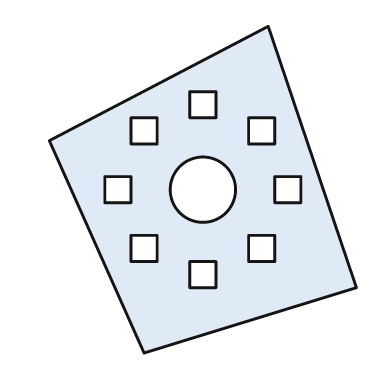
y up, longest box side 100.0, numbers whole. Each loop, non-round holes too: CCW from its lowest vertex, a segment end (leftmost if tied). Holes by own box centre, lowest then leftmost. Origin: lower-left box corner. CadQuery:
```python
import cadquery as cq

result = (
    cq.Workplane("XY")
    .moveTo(29.0, 0.0)
    .lineTo(94.0, 20.0)
    .lineTo(67.0, 100.0)
    .lineTo(0.0, 65.0)
    .close()
    .moveTo(43.0, 20.0)
    .lineTo(51.0, 20.0)
    .lineTo(51.0, 28.0)
    .lineTo(43.0, 28.0)
    .close()
    .moveTo(25.0, 28.0)
    .lineTo(33.0, 28.0)
    .lineTo(33.0, 36.0)
    .lineTo(25.0, 36.0)
    .close()
    .moveTo(61.0, 28.0)
    .lineTo(69.0, 28.0)
    .lineTo(69.0, 36.0)
    .lineTo(61.0, 36.0)
    .close()
    .moveTo(17.0, 46.0)
    .lineTo(25.0, 46.0)
    .lineTo(25.0, 54.0)
    .lineTo(17.0, 54.0)
    .close()
    .moveTo(47.0, 50.0)
    .circle(10.0)
    .moveTo(69.0, 46.0)
    .lineTo(77.0, 46.0)
    .lineTo(77.0, 54.0)
    .lineTo(69.0, 54.0)
    .close()
    .moveTo(25.0, 64.0)
    .lineTo(33.0, 64.0)
    .lineTo(33.0, 72.0)
    .lineTo(25.0, 72.0)
    .close()
    .moveTo(61.0, 64.0)
    .lineTo(69.0, 64.0)
    .lineTo(69.0, 72.0)
    .lineTo(61.0, 72.0)
    .close()
    .moveTo(43.0, 72.0)
    .lineTo(51.0, 72.0)
    .lineTo(51.0, 80.0)
    .lineTo(43.0, 80.0)
    .close()
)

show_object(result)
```